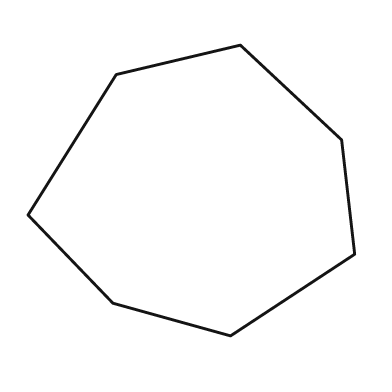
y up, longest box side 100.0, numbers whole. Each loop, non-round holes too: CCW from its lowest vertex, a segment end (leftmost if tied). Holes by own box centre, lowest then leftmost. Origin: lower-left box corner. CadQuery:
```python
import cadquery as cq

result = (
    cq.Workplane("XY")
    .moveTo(62.0, 0.0)
    .lineTo(100.0, 25.0)
    .lineTo(96.0, 60.0)
    .lineTo(65.0, 89.0)
    .lineTo(27.0, 80.0)
    .lineTo(0.0, 37.0)
    .lineTo(26.0, 10.0)
    .close()
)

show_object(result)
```